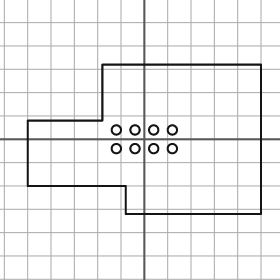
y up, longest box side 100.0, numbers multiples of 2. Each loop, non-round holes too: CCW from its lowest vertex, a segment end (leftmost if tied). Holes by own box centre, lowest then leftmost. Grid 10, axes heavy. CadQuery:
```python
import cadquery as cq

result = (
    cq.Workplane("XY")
    .moveTo(-8.0, -32.0)
    .lineTo(50.0, -32.0)
    .lineTo(50.0, 32.0)
    .lineTo(-18.0, 32.0)
    .lineTo(-18.0, 8.0)
    .lineTo(-50.0, 8.0)
    .lineTo(-50.0, -20.0)
    .lineTo(-8.0, -20.0)
    .close()
    .moveTo(-12.0, -4.0)
    .circle(2.0)
    .moveTo(-4.0, -4.0)
    .circle(2.0)
    .moveTo(4.0, -4.0)
    .circle(2.0)
    .moveTo(12.0, -4.0)
    .circle(2.0)
    .moveTo(-12.0, 4.0)
    .circle(2.0)
    .moveTo(-4.0, 4.0)
    .circle(2.0)
    .moveTo(4.0, 4.0)
    .circle(2.0)
    .moveTo(12.0, 4.0)
    .circle(2.0)
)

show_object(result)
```